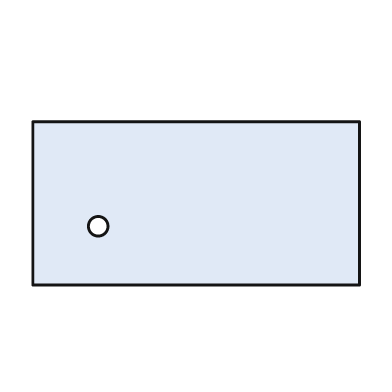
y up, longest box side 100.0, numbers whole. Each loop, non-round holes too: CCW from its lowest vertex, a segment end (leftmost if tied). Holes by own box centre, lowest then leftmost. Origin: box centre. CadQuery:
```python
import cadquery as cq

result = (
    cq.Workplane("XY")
    .moveTo(-50.0, -25.0)
    .lineTo(50.0, -25.0)
    .lineTo(50.0, 25.0)
    .lineTo(-50.0, 25.0)
    .close()
    .moveTo(-30.0, -7.0)
    .circle(3.0)
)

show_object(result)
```